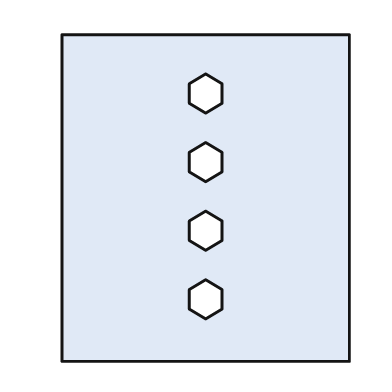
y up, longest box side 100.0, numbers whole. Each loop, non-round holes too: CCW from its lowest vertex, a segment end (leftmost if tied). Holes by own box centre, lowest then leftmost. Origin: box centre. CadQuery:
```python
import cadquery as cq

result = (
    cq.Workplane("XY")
    .moveTo(-44.0, -50.0)
    .lineTo(44.0, -50.0)
    .lineTo(44.0, 50.0)
    .lineTo(-44.0, 50.0)
    .close()
    .moveTo(0.0, -37.0)
    .lineTo(5.0, -34.0)
    .lineTo(5.0, -28.0)
    .lineTo(0.0, -25.0)
    .lineTo(-5.0, -28.0)
    .lineTo(-5.0, -34.0)
    .close()
    .moveTo(0.0, -16.0)
    .lineTo(5.0, -13.0)
    .lineTo(5.0, -7.0)
    .lineTo(0.0, -4.0)
    .lineTo(-5.0, -7.0)
    .lineTo(-5.0, -13.0)
    .close()
    .moveTo(0.0, 5.0)
    .lineTo(5.0, 8.0)
    .lineTo(5.0, 14.0)
    .lineTo(0.0, 17.0)
    .lineTo(-5.0, 14.0)
    .lineTo(-5.0, 8.0)
    .close()
    .moveTo(0.0, 26.0)
    .lineTo(5.0, 29.0)
    .lineTo(5.0, 35.0)
    .lineTo(0.0, 38.0)
    .lineTo(-5.0, 35.0)
    .lineTo(-5.0, 29.0)
    .close()
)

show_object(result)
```